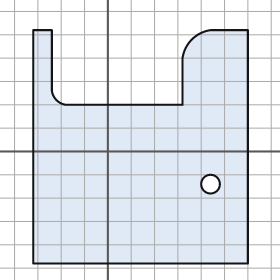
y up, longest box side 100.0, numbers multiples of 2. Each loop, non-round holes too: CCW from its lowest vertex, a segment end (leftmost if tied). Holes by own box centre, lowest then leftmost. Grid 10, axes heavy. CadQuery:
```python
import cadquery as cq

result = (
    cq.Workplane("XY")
    .moveTo(-32.0, -48.0)
    .lineTo(60.0, -48.0)
    .lineTo(60.0, 52.0)
    .lineTo(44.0, 52.0)
    .threePointArc((36.0, 48.0), (32.0, 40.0))
    .lineTo(32.0, 20.0)
    .lineTo(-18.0, 20.0)
    .threePointArc((-22.0, 22.0), (-24.0, 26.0))
    .lineTo(-24.0, 52.0)
    .lineTo(-32.0, 52.0)
    .close()
    .moveTo(44.0, -14.0)
    .circle(4.0)
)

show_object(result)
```